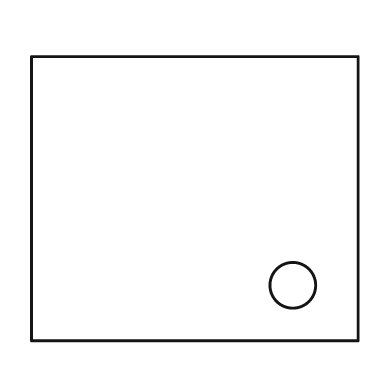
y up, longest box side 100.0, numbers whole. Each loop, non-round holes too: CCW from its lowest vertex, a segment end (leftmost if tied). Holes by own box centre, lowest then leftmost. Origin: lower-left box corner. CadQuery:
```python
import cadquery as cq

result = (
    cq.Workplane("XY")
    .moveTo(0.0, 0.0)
    .lineTo(100.0, 0.0)
    .lineTo(100.0, 87.0)
    .lineTo(0.0, 87.0)
    .close()
    .moveTo(80.0, 17.0)
    .circle(7.0)
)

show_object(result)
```